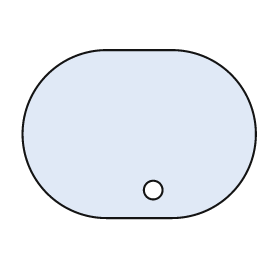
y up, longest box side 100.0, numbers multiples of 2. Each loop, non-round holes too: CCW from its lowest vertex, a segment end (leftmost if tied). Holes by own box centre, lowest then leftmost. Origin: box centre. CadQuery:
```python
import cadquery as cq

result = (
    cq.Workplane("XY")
    .moveTo(-14.0, -36.0)
    .lineTo(14.0, -36.0)
    .threePointArc((50.0, 0.0), (14.0, 36.0))
    .lineTo(-14.0, 36.0)
    .threePointArc((-50.0, 0.0), (-14.0, -36.0))
    .close()
    .moveTo(6.0, -24.0)
    .circle(4.0)
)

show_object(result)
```